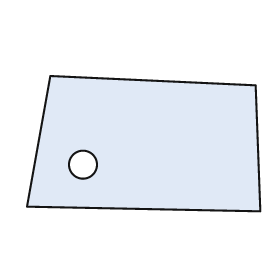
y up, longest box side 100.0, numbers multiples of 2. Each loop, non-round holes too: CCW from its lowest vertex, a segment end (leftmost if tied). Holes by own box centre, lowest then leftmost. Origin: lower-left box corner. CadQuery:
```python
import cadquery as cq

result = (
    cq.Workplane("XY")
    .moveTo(100.0, 0.0)
    .lineTo(98.0, 54.0)
    .lineTo(10.0, 58.0)
    .lineTo(0.0, 2.0)
    .close()
    .moveTo(24.0, 20.0)
    .circle(6.0)
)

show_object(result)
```